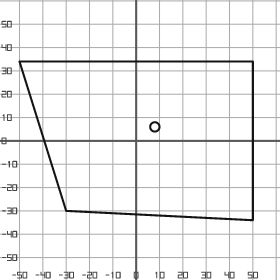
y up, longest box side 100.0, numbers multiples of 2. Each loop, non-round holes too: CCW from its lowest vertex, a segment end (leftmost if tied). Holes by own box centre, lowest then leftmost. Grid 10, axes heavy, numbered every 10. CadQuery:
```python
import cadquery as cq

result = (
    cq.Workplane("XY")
    .moveTo(50.0, -34.0)
    .lineTo(50.0, 34.0)
    .lineTo(-50.0, 34.0)
    .lineTo(-30.0, -30.0)
    .close()
    .moveTo(8.0, 6.0)
    .circle(2.0)
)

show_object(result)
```